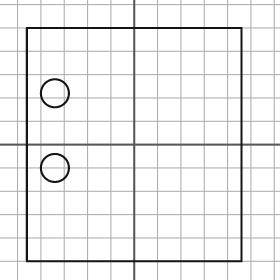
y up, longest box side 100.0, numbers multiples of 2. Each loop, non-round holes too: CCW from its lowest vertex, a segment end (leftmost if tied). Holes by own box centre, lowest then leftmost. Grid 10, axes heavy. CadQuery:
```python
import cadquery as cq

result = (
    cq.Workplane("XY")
    .moveTo(-46.0, -50.0)
    .lineTo(46.0, -50.0)
    .lineTo(46.0, 50.0)
    .lineTo(-46.0, 50.0)
    .close()
    .moveTo(-34.0, -10.0)
    .circle(6.0)
    .moveTo(-34.0, 22.0)
    .circle(6.0)
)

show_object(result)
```